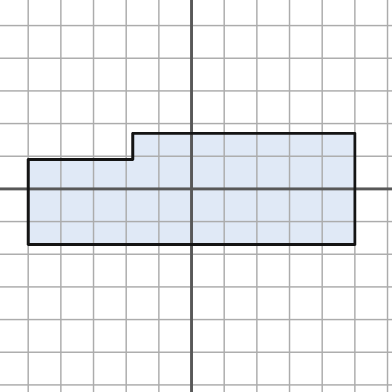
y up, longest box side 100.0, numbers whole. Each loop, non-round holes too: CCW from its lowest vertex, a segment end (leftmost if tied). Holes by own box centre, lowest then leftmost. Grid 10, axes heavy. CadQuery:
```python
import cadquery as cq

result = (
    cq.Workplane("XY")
    .moveTo(-50.0, -17.0)
    .lineTo(50.0, -17.0)
    .lineTo(50.0, 17.0)
    .lineTo(-18.0, 17.0)
    .lineTo(-18.0, 9.0)
    .lineTo(-50.0, 9.0)
    .close()
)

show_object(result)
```